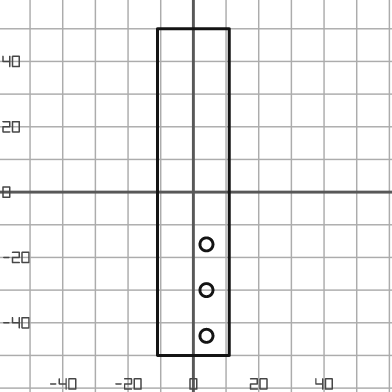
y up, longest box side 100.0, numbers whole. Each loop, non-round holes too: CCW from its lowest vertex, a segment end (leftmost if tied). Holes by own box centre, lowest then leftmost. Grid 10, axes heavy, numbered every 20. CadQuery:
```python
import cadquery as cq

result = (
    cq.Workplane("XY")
    .moveTo(-11.0, -50.0)
    .lineTo(11.0, -50.0)
    .lineTo(11.0, 50.0)
    .lineTo(-11.0, 50.0)
    .close()
    .moveTo(4.0, -44.0)
    .circle(2.0)
    .moveTo(4.0, -30.0)
    .circle(2.0)
    .moveTo(4.0, -16.0)
    .circle(2.0)
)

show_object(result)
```